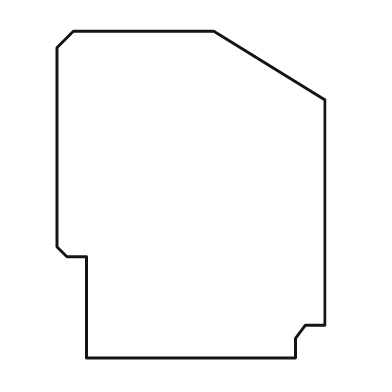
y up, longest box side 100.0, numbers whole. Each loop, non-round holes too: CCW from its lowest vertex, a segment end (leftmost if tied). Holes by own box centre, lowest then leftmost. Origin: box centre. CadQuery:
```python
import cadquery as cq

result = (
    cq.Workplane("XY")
    .moveTo(-32.0, -50.0)
    .lineTo(32.0, -50.0)
    .lineTo(32.0, -44.0)
    .lineTo(35.0, -40.0)
    .lineTo(41.0, -40.0)
    .lineTo(41.0, 29.0)
    .lineTo(7.0, 50.0)
    .lineTo(-36.0, 50.0)
    .lineTo(-41.0, 45.0)
    .lineTo(-41.0, -16.0)
    .lineTo(-38.0, -19.0)
    .lineTo(-32.0, -19.0)
    .close()
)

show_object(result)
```